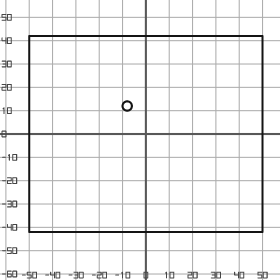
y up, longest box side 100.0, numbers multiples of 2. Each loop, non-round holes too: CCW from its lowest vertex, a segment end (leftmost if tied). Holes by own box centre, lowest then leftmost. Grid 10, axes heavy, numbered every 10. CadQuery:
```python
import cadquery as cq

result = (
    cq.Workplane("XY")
    .moveTo(-50.0, -42.0)
    .lineTo(50.0, -42.0)
    .lineTo(50.0, 42.0)
    .lineTo(-50.0, 42.0)
    .close()
    .moveTo(-8.0, 12.0)
    .circle(2.0)
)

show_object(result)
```